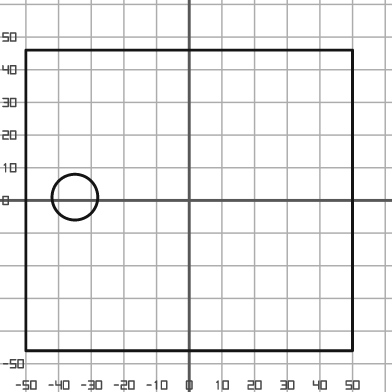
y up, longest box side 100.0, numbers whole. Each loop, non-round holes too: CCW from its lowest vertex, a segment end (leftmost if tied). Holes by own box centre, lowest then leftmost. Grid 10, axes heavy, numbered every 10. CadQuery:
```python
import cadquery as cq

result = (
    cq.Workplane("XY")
    .moveTo(-50.0, -46.0)
    .lineTo(50.0, -46.0)
    .lineTo(50.0, 46.0)
    .lineTo(-50.0, 46.0)
    .close()
    .moveTo(-35.0, 1.0)
    .circle(7.0)
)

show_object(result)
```